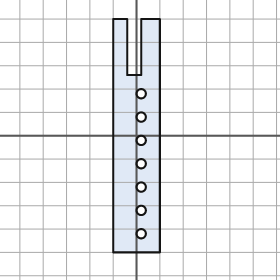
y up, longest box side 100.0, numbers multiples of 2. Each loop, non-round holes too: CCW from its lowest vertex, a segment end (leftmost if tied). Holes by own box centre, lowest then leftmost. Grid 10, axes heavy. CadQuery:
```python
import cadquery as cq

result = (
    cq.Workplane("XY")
    .moveTo(-10.0, -50.0)
    .lineTo(10.0, -50.0)
    .lineTo(10.0, 50.0)
    .lineTo(2.0, 50.0)
    .lineTo(2.0, 26.0)
    .lineTo(-4.0, 26.0)
    .lineTo(-4.0, 50.0)
    .lineTo(-10.0, 50.0)
    .close()
    .moveTo(2.0, -42.0)
    .circle(2.0)
    .moveTo(2.0, -32.0)
    .circle(2.0)
    .moveTo(2.0, -22.0)
    .circle(2.0)
    .moveTo(2.0, -12.0)
    .circle(2.0)
    .moveTo(2.0, -2.0)
    .circle(2.0)
    .moveTo(2.0, 8.0)
    .circle(2.0)
    .moveTo(2.0, 18.0)
    .circle(2.0)
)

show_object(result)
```